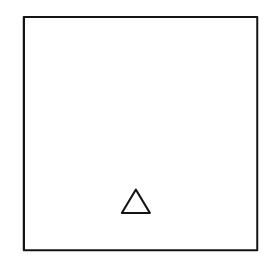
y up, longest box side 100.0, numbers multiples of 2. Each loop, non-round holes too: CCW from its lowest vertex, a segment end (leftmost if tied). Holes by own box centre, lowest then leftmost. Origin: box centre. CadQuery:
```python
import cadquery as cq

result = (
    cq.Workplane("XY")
    .moveTo(-50.0, -50.0)
    .lineTo(50.0, -50.0)
    .lineTo(50.0, 50.0)
    .lineTo(-50.0, 50.0)
    .close()
    .moveTo(-8.0, -34.0)
    .lineTo(4.0, -34.0)
    .lineTo(-2.0, -24.0)
    .close()
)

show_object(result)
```